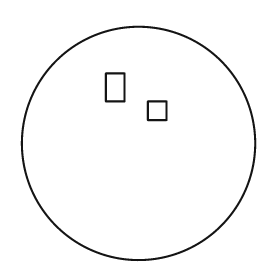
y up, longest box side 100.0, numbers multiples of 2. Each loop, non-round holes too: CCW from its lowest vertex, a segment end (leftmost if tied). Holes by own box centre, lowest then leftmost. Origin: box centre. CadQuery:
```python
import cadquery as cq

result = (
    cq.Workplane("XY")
    .moveTo(0.0, 0.0)
    .circle(50.0)
    .moveTo(4.0, 10.0)
    .lineTo(12.0, 10.0)
    .lineTo(12.0, 18.0)
    .lineTo(4.0, 18.0)
    .close()
    .moveTo(-14.0, 18.0)
    .lineTo(-6.0, 18.0)
    .lineTo(-6.0, 30.0)
    .lineTo(-14.0, 30.0)
    .close()
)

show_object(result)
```